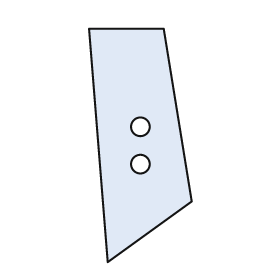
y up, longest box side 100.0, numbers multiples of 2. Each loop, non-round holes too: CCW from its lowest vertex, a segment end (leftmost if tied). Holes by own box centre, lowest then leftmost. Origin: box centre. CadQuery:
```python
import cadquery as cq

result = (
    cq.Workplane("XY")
    .moveTo(-14.0, -50.0)
    .lineTo(22.0, -24.0)
    .lineTo(10.0, 50.0)
    .lineTo(-22.0, 50.0)
    .close()
    .moveTo(0.0, -8.0)
    .circle(4.0)
    .moveTo(0.0, 8.0)
    .circle(4.0)
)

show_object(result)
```